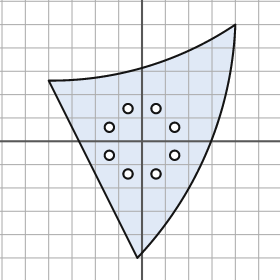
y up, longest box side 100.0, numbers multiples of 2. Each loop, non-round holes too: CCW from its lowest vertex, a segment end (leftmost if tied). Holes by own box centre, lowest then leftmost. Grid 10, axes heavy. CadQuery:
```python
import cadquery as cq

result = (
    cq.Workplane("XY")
    .moveTo(-2.0, -50.0)
    .threePointArc((28.0, -4.0), (40.0, 50.0))
    .threePointArc((2.0, 32.0), (-40.0, 26.0))
    .close()
    .moveTo(-6.0, -14.0)
    .circle(2.0)
    .moveTo(6.0, -14.0)
    .circle(2.0)
    .moveTo(-14.0, -6.0)
    .circle(2.0)
    .moveTo(14.0, -6.0)
    .circle(2.0)
    .moveTo(-14.0, 6.0)
    .circle(2.0)
    .moveTo(14.0, 6.0)
    .circle(2.0)
    .moveTo(-6.0, 14.0)
    .circle(2.0)
    .moveTo(6.0, 14.0)
    .circle(2.0)
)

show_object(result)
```